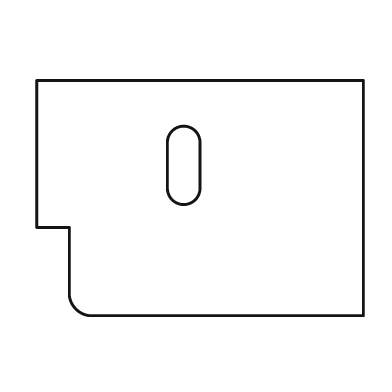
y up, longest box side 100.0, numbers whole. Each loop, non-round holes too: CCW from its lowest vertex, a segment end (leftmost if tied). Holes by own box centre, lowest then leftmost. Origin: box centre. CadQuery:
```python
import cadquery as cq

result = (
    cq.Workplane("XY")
    .moveTo(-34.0, -36.0)
    .lineTo(50.0, -36.0)
    .lineTo(50.0, 36.0)
    .lineTo(-50.0, 36.0)
    .lineTo(-50.0, -9.0)
    .lineTo(-40.0, -9.0)
    .lineTo(-40.0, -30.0)
    .threePointArc((-38.0, -34.0), (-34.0, -36.0))
    .close()
    .moveTo(-10.0, 3.0)
    .threePointArc((-5.0, -2.0), (0.0, 3.0))
    .lineTo(0.0, 17.0)
    .threePointArc((-5.0, 22.0), (-10.0, 17.0))
    .close()
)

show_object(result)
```